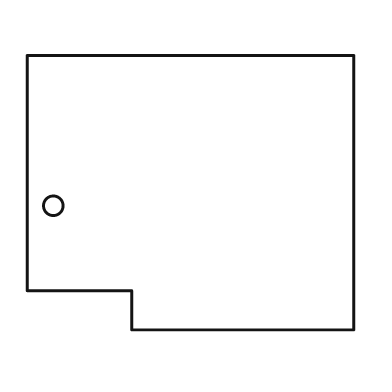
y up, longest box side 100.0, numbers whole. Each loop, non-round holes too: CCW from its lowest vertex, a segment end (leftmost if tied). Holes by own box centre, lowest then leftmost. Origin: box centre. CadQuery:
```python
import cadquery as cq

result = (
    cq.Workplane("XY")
    .moveTo(-18.0, -42.0)
    .lineTo(50.0, -42.0)
    .lineTo(50.0, 42.0)
    .lineTo(-50.0, 42.0)
    .lineTo(-50.0, -30.0)
    .lineTo(-18.0, -30.0)
    .close()
    .moveTo(-42.0, -4.0)
    .circle(3.0)
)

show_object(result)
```